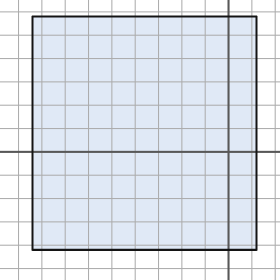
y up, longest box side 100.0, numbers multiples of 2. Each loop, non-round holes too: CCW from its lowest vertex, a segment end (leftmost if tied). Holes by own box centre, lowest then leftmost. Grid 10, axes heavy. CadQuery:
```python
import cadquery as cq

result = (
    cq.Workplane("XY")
    .moveTo(-84.0, -42.0)
    .lineTo(12.0, -42.0)
    .lineTo(12.0, 58.0)
    .lineTo(-84.0, 58.0)
    .close()
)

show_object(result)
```